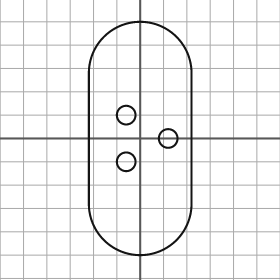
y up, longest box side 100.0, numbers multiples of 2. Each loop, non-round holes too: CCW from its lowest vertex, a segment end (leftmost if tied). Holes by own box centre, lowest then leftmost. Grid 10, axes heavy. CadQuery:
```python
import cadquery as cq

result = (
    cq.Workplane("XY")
    .moveTo(-22.0, -28.0)
    .threePointArc((0.0, -50.0), (22.0, -28.0))
    .lineTo(22.0, 28.0)
    .threePointArc((0.0, 50.0), (-22.0, 28.0))
    .close()
    .moveTo(-6.0, -10.0)
    .circle(4.0)
    .moveTo(12.0, 0.0)
    .circle(4.0)
    .moveTo(-6.0, 10.0)
    .circle(4.0)
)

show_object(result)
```